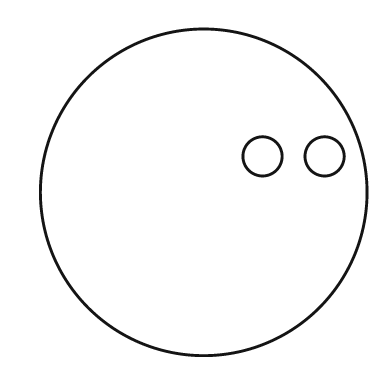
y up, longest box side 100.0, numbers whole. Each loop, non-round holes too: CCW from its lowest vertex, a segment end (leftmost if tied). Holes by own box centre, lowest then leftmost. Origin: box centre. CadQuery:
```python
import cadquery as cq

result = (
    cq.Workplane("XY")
    .moveTo(0.0, 0.0)
    .circle(50.0)
    .moveTo(18.0, 11.0)
    .circle(6.0)
    .moveTo(37.0, 11.0)
    .circle(6.0)
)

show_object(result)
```